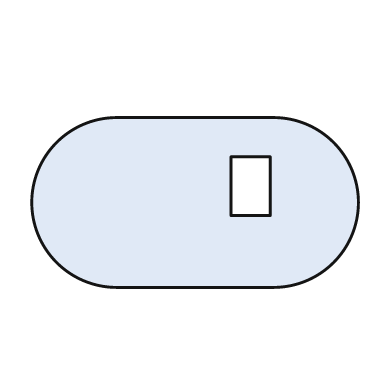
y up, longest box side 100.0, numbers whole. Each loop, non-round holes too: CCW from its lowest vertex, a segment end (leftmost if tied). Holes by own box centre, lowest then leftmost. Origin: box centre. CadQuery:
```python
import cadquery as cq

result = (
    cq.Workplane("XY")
    .moveTo(-24.0, -26.0)
    .lineTo(24.0, -26.0)
    .threePointArc((50.0, 0.0), (24.0, 26.0))
    .lineTo(-24.0, 26.0)
    .threePointArc((-50.0, 0.0), (-24.0, -26.0))
    .close()
    .moveTo(11.0, -4.0)
    .lineTo(23.0, -4.0)
    .lineTo(23.0, 14.0)
    .lineTo(11.0, 14.0)
    .close()
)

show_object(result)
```